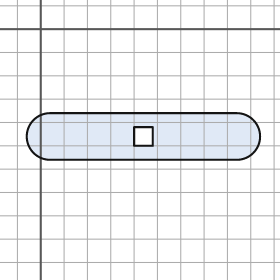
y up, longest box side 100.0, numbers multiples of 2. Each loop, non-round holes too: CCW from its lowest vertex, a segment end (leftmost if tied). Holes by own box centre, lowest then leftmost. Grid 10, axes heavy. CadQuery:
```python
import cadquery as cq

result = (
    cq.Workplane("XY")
    .moveTo(4.0, -56.0)
    .lineTo(84.0, -56.0)
    .threePointArc((94.0, -46.0), (84.0, -36.0))
    .lineTo(4.0, -36.0)
    .threePointArc((-6.0, -46.0), (4.0, -56.0))
    .close()
    .moveTo(40.0, -50.0)
    .lineTo(48.0, -50.0)
    .lineTo(48.0, -42.0)
    .lineTo(40.0, -42.0)
    .close()
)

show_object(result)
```